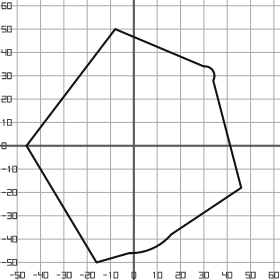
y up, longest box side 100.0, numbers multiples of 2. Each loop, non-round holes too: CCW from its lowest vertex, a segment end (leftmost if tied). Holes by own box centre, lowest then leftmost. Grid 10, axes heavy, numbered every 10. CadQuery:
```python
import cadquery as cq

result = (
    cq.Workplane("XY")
    .moveTo(-16.0, -50.0)
    .lineTo(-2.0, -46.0)
    .threePointArc((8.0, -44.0), (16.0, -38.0))
    .lineTo(46.0, -18.0)
    .lineTo(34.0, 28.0)
    .threePointArc((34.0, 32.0), (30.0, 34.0))
    .lineTo(-8.0, 50.0)
    .lineTo(-46.0, 0.0)
    .close()
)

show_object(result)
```